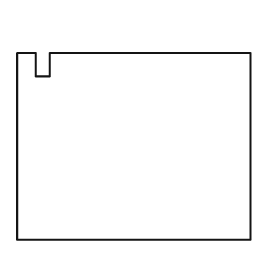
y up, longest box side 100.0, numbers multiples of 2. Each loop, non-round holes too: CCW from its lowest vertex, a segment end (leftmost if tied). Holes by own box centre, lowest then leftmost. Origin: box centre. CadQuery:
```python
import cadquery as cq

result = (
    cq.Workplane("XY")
    .moveTo(-50.0, -40.0)
    .lineTo(50.0, -40.0)
    .lineTo(50.0, 40.0)
    .lineTo(-36.0, 40.0)
    .lineTo(-36.0, 30.0)
    .lineTo(-42.0, 30.0)
    .lineTo(-42.0, 40.0)
    .lineTo(-50.0, 40.0)
    .close()
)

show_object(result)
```